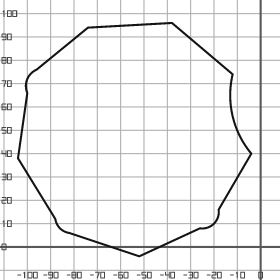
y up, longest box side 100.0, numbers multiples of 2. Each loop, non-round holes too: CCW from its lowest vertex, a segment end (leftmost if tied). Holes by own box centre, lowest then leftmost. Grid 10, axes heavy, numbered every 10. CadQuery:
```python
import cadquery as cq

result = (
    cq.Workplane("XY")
    .moveTo(-52.0, -4.0)
    .lineTo(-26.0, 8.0)
    .threePointArc((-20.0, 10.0), (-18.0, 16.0))
    .lineTo(-4.0, 40.0)
    .threePointArc((-12.0, 56.0), (-12.0, 74.0))
    .lineTo(-38.0, 96.0)
    .lineTo(-74.0, 94.0)
    .lineTo(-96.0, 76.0)
    .threePointArc((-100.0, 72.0), (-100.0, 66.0))
    .lineTo(-104.0, 38.0)
    .lineTo(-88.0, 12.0)
    .threePointArc((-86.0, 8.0), (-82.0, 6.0))
    .close()
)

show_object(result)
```